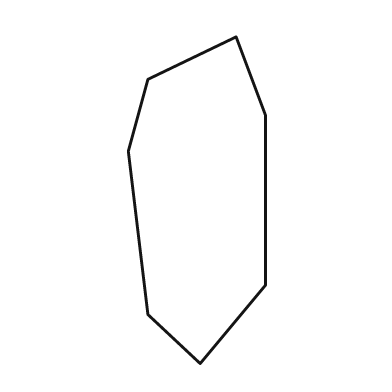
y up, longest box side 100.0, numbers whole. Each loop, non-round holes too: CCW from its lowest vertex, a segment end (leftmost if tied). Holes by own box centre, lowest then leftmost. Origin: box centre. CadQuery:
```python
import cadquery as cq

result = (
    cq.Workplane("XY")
    .moveTo(1.0, -50.0)
    .lineTo(21.0, -26.0)
    .lineTo(21.0, 26.0)
    .lineTo(12.0, 50.0)
    .lineTo(-15.0, 37.0)
    .lineTo(-21.0, 15.0)
    .lineTo(-15.0, -35.0)
    .close()
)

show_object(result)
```